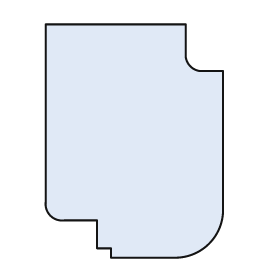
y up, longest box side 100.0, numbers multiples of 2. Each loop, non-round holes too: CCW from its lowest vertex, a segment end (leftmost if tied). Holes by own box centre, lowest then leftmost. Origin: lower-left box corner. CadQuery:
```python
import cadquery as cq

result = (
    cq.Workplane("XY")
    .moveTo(28.0, 0.0)
    .lineTo(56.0, 0.0)
    .threePointArc((70.0, 6.0), (76.0, 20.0))
    .lineTo(76.0, 80.0)
    .lineTo(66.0, 80.0)
    .threePointArc((62.0, 82.0), (60.0, 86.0))
    .lineTo(60.0, 100.0)
    .lineTo(0.0, 100.0)
    .lineTo(0.0, 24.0)
    .threePointArc((2.0, 18.0), (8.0, 16.0))
    .lineTo(22.0, 16.0)
    .lineTo(22.0, 4.0)
    .lineTo(28.0, 4.0)
    .close()
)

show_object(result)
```